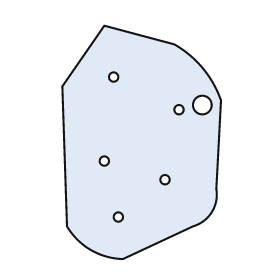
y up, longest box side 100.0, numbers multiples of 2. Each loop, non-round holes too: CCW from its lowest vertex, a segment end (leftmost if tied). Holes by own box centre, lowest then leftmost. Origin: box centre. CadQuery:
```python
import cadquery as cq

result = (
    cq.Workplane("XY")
    .moveTo(-8.0, -50.0)
    .lineTo(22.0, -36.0)
    .threePointArc((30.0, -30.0), (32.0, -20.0))
    .lineTo(34.0, 18.0)
    .threePointArc((26.0, 32.0), (14.0, 42.0))
    .lineTo(-16.0, 50.0)
    .lineTo(-34.0, 24.0)
    .lineTo(-32.0, -36.0)
    .threePointArc((-22.0, -46.0), (-8.0, -50.0))
    .close()
    .moveTo(-10.0, -32.0)
    .circle(2.0)
    .moveTo(10.0, -16.0)
    .circle(2.0)
    .moveTo(-16.0, -8.0)
    .circle(2.0)
    .moveTo(16.0, 14.0)
    .circle(2.0)
    .moveTo(26.0, 16.0)
    .circle(4.0)
    .moveTo(-12.0, 28.0)
    .circle(2.0)
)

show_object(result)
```